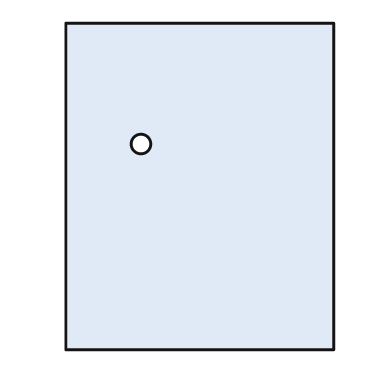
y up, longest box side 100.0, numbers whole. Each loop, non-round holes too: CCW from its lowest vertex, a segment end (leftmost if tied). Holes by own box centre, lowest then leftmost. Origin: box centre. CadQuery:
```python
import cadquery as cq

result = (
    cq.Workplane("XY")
    .moveTo(-41.0, -50.0)
    .lineTo(41.0, -50.0)
    .lineTo(41.0, 50.0)
    .lineTo(-41.0, 50.0)
    .close()
    .moveTo(-18.0, 13.0)
    .circle(3.0)
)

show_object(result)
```